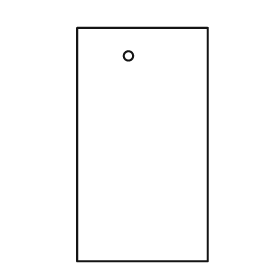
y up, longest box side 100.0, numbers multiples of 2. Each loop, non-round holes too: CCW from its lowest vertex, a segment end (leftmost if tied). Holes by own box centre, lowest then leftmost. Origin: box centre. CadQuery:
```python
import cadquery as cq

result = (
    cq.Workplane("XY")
    .moveTo(-28.0, -50.0)
    .lineTo(28.0, -50.0)
    .lineTo(28.0, 50.0)
    .lineTo(-28.0, 50.0)
    .close()
    .moveTo(-6.0, 38.0)
    .circle(2.0)
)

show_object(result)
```